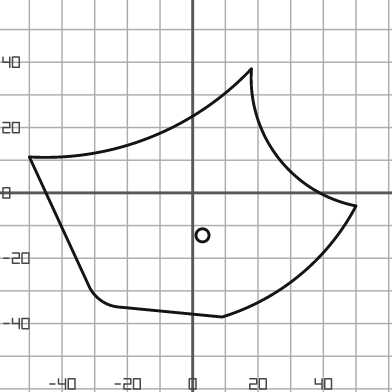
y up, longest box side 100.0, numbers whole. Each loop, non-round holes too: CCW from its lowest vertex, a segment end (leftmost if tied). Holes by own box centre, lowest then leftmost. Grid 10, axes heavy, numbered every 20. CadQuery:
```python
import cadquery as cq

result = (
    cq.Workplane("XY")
    .moveTo(9.0, -38.0)
    .threePointArc((33.0, -25.0), (50.0, -4.0))
    .threePointArc((26.0, 11.0), (18.0, 38.0))
    .threePointArc((-13.0, 17.0), (-50.0, 11.0))
    .lineTo(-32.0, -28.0)
    .threePointArc((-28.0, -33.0), (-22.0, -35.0))
    .close()
    .moveTo(3.0, -13.0)
    .circle(2.0)
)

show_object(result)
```